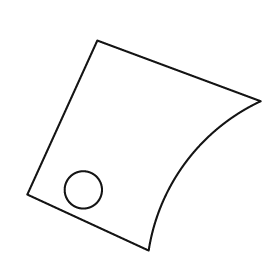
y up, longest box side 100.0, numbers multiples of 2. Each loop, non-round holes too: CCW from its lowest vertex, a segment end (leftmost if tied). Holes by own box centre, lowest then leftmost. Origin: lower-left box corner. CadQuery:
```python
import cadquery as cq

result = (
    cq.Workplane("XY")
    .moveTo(52.0, 0.0)
    .threePointArc((68.0, 38.0), (100.0, 64.0))
    .lineTo(30.0, 90.0)
    .lineTo(0.0, 24.0)
    .close()
    .moveTo(24.0, 26.0)
    .circle(8.0)
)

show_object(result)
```